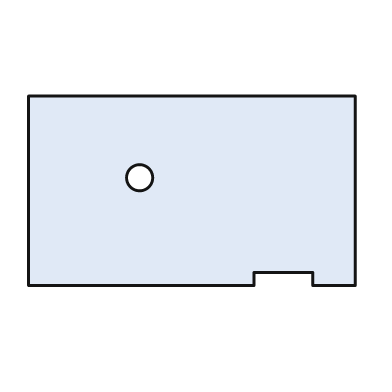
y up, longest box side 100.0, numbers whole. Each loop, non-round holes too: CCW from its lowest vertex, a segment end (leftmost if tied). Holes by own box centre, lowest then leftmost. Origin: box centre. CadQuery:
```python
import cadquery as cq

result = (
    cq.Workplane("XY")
    .moveTo(-50.0, -29.0)
    .lineTo(19.0, -29.0)
    .lineTo(19.0, -25.0)
    .lineTo(37.0, -25.0)
    .lineTo(37.0, -29.0)
    .lineTo(50.0, -29.0)
    .lineTo(50.0, 29.0)
    .lineTo(-50.0, 29.0)
    .close()
    .moveTo(-16.0, 4.0)
    .circle(4.0)
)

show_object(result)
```